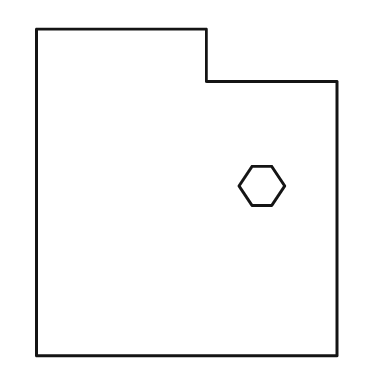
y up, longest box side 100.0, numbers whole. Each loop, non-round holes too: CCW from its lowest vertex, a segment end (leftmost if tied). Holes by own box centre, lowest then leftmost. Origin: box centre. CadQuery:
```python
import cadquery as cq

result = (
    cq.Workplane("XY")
    .moveTo(-46.0, -50.0)
    .lineTo(46.0, -50.0)
    .lineTo(46.0, 34.0)
    .lineTo(6.0, 34.0)
    .lineTo(6.0, 50.0)
    .lineTo(-46.0, 50.0)
    .close()
    .moveTo(20.0, -4.0)
    .lineTo(26.0, -4.0)
    .lineTo(30.0, 2.0)
    .lineTo(26.0, 8.0)
    .lineTo(20.0, 8.0)
    .lineTo(16.0, 2.0)
    .close()
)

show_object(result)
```